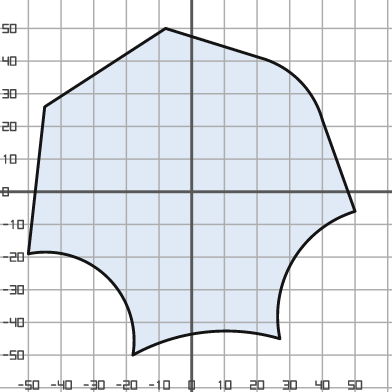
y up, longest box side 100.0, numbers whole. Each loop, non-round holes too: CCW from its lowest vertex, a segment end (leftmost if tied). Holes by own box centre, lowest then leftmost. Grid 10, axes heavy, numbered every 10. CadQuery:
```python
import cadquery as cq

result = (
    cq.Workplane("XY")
    .moveTo(-18.0, -50.0)
    .threePointArc((4.0, -43.0), (27.0, -45.0))
    .threePointArc((31.0, -21.0), (50.0, -6.0))
    .lineTo(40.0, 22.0)
    .threePointArc((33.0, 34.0), (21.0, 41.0))
    .lineTo(-8.0, 50.0)
    .lineTo(-45.0, 26.0)
    .lineTo(-50.0, -19.0)
    .threePointArc((-26.0, -26.0), (-18.0, -50.0))
    .close()
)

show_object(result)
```